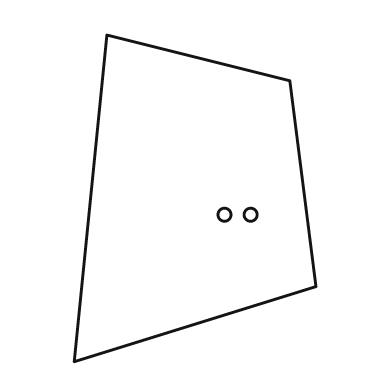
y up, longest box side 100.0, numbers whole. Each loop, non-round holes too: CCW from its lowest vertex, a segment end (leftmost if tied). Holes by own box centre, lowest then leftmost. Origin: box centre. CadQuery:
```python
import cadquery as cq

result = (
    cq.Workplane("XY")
    .moveTo(-37.0, -50.0)
    .lineTo(37.0, -27.0)
    .lineTo(29.0, 36.0)
    .lineTo(-27.0, 50.0)
    .close()
    .moveTo(9.0, -5.0)
    .circle(2.0)
    .moveTo(17.0, -5.0)
    .circle(2.0)
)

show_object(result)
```